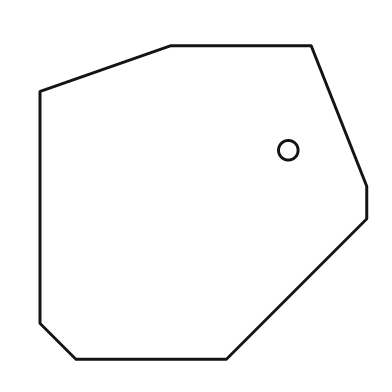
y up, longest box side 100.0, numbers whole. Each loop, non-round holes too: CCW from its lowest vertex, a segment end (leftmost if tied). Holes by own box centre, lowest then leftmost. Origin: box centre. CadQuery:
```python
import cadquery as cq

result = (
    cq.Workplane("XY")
    .moveTo(-39.0, -48.0)
    .lineTo(7.0, -48.0)
    .lineTo(50.0, -5.0)
    .lineTo(50.0, 5.0)
    .lineTo(33.0, 48.0)
    .lineTo(-10.0, 48.0)
    .lineTo(-50.0, 34.0)
    .lineTo(-50.0, -37.0)
    .close()
    .moveTo(26.0, 16.0)
    .circle(3.0)
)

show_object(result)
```